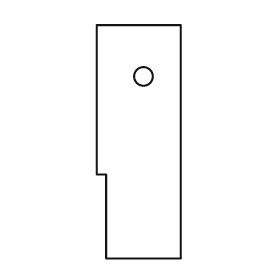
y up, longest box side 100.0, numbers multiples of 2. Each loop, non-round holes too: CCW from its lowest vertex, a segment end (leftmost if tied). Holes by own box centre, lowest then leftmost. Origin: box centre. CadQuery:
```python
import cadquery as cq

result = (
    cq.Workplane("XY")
    .moveTo(-14.0, -50.0)
    .lineTo(18.0, -50.0)
    .lineTo(18.0, 50.0)
    .lineTo(-18.0, 50.0)
    .lineTo(-18.0, -14.0)
    .lineTo(-14.0, -14.0)
    .close()
    .moveTo(2.0, 28.0)
    .circle(4.0)
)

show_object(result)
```